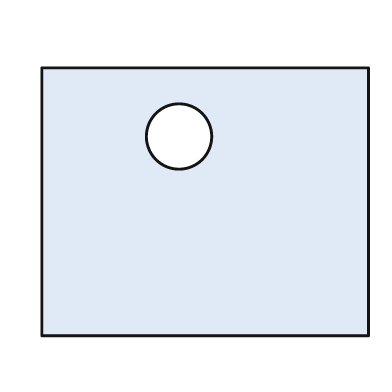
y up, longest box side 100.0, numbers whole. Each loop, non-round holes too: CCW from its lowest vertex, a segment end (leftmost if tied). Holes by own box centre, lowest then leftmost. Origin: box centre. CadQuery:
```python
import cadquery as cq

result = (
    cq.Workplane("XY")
    .moveTo(-50.0, -41.0)
    .lineTo(50.0, -41.0)
    .lineTo(50.0, 41.0)
    .lineTo(-50.0, 41.0)
    .close()
    .moveTo(-8.0, 20.0)
    .circle(10.0)
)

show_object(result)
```